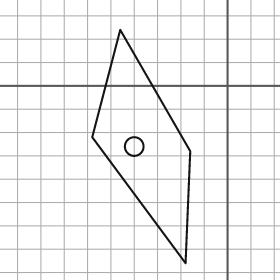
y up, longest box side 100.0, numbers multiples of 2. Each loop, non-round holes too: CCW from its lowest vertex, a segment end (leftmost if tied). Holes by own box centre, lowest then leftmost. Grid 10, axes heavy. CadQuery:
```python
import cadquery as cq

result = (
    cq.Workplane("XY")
    .moveTo(-18.0, -76.0)
    .lineTo(-16.0, -28.0)
    .lineTo(-46.0, 24.0)
    .lineTo(-58.0, -22.0)
    .close()
    .moveTo(-40.0, -26.0)
    .circle(4.0)
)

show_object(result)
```